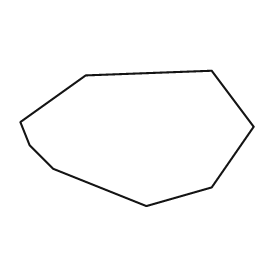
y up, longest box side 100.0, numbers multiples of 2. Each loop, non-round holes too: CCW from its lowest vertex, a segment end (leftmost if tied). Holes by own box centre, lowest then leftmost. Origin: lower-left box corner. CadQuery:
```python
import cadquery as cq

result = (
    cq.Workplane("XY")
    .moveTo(54.0, 0.0)
    .lineTo(82.0, 8.0)
    .lineTo(100.0, 34.0)
    .lineTo(82.0, 58.0)
    .lineTo(28.0, 56.0)
    .lineTo(0.0, 36.0)
    .lineTo(4.0, 26.0)
    .lineTo(14.0, 16.0)
    .close()
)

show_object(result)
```